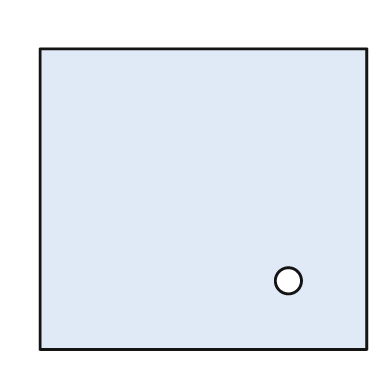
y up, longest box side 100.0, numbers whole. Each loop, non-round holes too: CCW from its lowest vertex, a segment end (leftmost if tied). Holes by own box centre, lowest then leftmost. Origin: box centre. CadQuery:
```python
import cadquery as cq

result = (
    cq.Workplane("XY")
    .moveTo(-50.0, -46.0)
    .lineTo(50.0, -46.0)
    .lineTo(50.0, 46.0)
    .lineTo(-50.0, 46.0)
    .close()
    .moveTo(26.0, -25.0)
    .circle(4.0)
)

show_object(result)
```